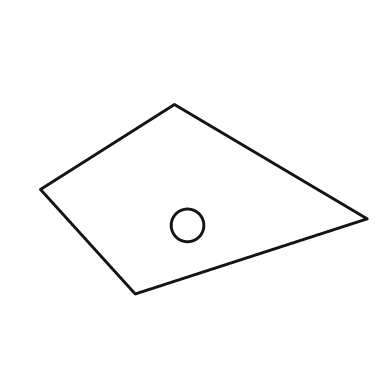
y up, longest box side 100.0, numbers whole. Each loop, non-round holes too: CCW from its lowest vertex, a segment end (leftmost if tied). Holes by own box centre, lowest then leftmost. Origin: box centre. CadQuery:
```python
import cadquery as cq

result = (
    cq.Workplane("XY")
    .moveTo(-21.0, -29.0)
    .lineTo(50.0, -6.0)
    .lineTo(-9.0, 29.0)
    .lineTo(-50.0, 3.0)
    .close()
    .moveTo(-5.0, -8.0)
    .circle(5.0)
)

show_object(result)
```